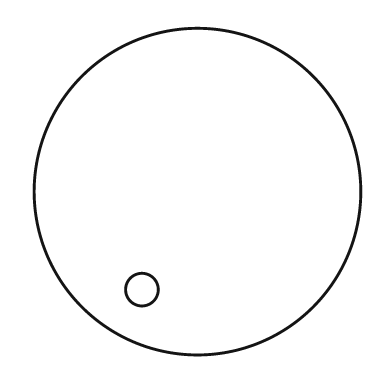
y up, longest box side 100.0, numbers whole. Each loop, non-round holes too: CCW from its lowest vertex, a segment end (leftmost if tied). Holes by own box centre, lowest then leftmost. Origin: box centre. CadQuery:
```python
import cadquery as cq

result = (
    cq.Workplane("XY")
    .moveTo(0.0, 0.0)
    .circle(50.0)
    .moveTo(-17.0, -30.0)
    .circle(5.0)
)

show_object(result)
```